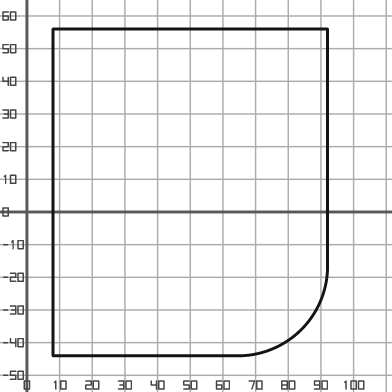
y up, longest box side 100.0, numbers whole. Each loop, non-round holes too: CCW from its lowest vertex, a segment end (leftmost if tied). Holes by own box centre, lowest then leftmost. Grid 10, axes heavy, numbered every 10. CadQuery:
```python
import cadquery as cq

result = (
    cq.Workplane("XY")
    .moveTo(8.0, -44.0)
    .lineTo(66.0, -44.0)
    .threePointArc((84.0, -36.0), (92.0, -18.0))
    .lineTo(92.0, 56.0)
    .lineTo(8.0, 56.0)
    .close()
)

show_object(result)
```